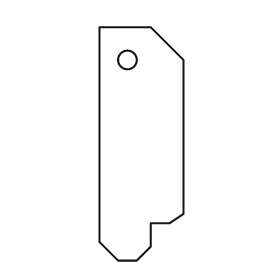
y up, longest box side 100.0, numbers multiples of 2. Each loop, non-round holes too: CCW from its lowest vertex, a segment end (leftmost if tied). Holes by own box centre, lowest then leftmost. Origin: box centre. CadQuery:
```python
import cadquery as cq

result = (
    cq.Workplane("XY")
    .moveTo(-10.0, -50.0)
    .lineTo(-2.0, -50.0)
    .lineTo(4.0, -44.0)
    .lineTo(4.0, -34.0)
    .lineTo(12.0, -34.0)
    .lineTo(18.0, -30.0)
    .lineTo(18.0, 36.0)
    .lineTo(4.0, 50.0)
    .lineTo(-18.0, 50.0)
    .lineTo(-18.0, -42.0)
    .close()
    .moveTo(-6.0, 36.0)
    .circle(4.0)
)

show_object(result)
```